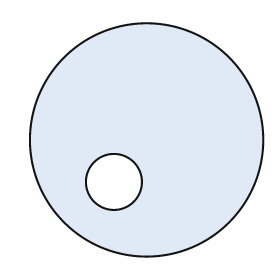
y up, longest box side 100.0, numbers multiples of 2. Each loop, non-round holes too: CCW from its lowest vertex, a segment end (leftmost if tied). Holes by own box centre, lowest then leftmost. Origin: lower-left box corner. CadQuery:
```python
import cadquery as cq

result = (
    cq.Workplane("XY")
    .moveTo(50.0, 50.0)
    .circle(50.0)
    .moveTo(36.0, 32.0)
    .circle(12.0)
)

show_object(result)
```